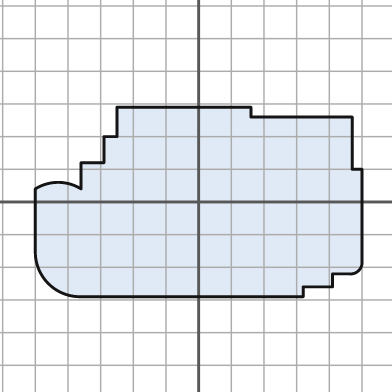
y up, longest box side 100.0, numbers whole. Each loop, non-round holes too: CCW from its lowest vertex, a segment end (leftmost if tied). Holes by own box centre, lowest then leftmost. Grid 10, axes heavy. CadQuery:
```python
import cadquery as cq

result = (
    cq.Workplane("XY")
    .moveTo(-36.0, -29.0)
    .lineTo(32.0, -29.0)
    .lineTo(32.0, -26.0)
    .lineTo(41.0, -26.0)
    .lineTo(41.0, -22.0)
    .lineTo(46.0, -22.0)
    .threePointArc((49.0, -21.0), (50.0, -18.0))
    .lineTo(50.0, 10.0)
    .lineTo(47.0, 10.0)
    .lineTo(47.0, 26.0)
    .lineTo(16.0, 26.0)
    .lineTo(16.0, 29.0)
    .lineTo(-25.0, 29.0)
    .lineTo(-25.0, 20.0)
    .lineTo(-29.0, 20.0)
    .lineTo(-29.0, 12.0)
    .lineTo(-36.0, 12.0)
    .lineTo(-36.0, 4.0)
    .threePointArc((-43.0, 6.0), (-50.0, 4.0))
    .lineTo(-50.0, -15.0)
    .threePointArc((-46.0, -25.0), (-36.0, -29.0))
    .close()
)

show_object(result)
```